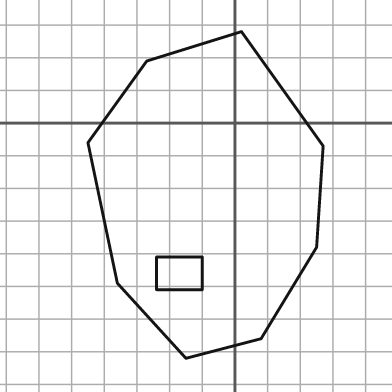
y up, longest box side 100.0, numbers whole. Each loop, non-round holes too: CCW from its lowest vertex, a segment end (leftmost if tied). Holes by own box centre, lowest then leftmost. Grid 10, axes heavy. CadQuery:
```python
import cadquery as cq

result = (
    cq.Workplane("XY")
    .moveTo(-15.0, -72.0)
    .lineTo(8.0, -66.0)
    .lineTo(25.0, -38.0)
    .lineTo(27.0, -7.0)
    .lineTo(2.0, 28.0)
    .lineTo(-27.0, 19.0)
    .lineTo(-45.0, -6.0)
    .lineTo(-36.0, -49.0)
    .close()
    .moveTo(-24.0, -51.0)
    .lineTo(-10.0, -51.0)
    .lineTo(-10.0, -41.0)
    .lineTo(-24.0, -41.0)
    .close()
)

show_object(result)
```